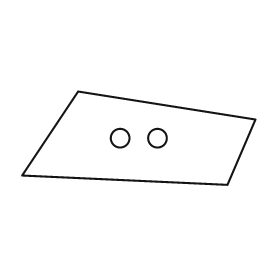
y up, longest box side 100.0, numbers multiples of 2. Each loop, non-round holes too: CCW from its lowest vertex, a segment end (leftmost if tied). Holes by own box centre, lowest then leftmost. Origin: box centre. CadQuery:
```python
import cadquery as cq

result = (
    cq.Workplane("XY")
    .moveTo(38.0, -20.0)
    .lineTo(50.0, 8.0)
    .lineTo(-26.0, 20.0)
    .lineTo(-50.0, -16.0)
    .close()
    .moveTo(-8.0, 0.0)
    .circle(4.0)
    .moveTo(8.0, 0.0)
    .circle(4.0)
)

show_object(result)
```